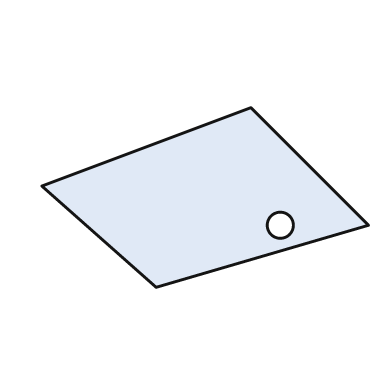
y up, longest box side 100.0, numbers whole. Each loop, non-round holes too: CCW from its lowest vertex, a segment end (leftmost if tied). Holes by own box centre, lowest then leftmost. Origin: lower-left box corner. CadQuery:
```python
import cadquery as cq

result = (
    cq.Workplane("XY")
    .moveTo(35.0, 0.0)
    .lineTo(100.0, 19.0)
    .lineTo(64.0, 55.0)
    .lineTo(0.0, 31.0)
    .close()
    .moveTo(73.0, 19.0)
    .circle(4.0)
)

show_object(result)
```